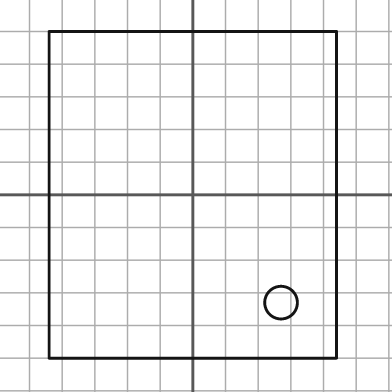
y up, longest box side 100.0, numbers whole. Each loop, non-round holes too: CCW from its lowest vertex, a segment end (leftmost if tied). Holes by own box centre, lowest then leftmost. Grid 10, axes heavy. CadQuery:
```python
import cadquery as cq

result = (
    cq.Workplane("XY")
    .moveTo(-44.0, -50.0)
    .lineTo(44.0, -50.0)
    .lineTo(44.0, 50.0)
    .lineTo(-44.0, 50.0)
    .close()
    .moveTo(27.0, -33.0)
    .circle(5.0)
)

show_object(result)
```